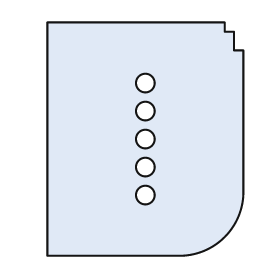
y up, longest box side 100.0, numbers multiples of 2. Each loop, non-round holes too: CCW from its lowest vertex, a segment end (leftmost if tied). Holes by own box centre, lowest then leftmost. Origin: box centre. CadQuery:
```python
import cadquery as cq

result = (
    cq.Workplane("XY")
    .moveTo(-42.0, -50.0)
    .lineTo(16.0, -50.0)
    .threePointArc((34.0, -42.0), (42.0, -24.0))
    .lineTo(42.0, 38.0)
    .lineTo(38.0, 38.0)
    .lineTo(38.0, 46.0)
    .lineTo(34.0, 46.0)
    .lineTo(34.0, 50.0)
    .lineTo(-42.0, 50.0)
    .close()
    .moveTo(0.0, -24.0)
    .circle(4.0)
    .moveTo(0.0, -12.0)
    .circle(4.0)
    .moveTo(0.0, 0.0)
    .circle(4.0)
    .moveTo(0.0, 12.0)
    .circle(4.0)
    .moveTo(0.0, 24.0)
    .circle(4.0)
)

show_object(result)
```